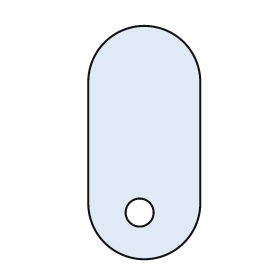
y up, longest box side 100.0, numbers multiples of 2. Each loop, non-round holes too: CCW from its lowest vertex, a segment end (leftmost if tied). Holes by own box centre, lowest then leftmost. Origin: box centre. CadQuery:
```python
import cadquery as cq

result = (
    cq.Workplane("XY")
    .moveTo(-24.0, -26.0)
    .threePointArc((0.0, -50.0), (24.0, -26.0))
    .lineTo(24.0, 26.0)
    .threePointArc((0.0, 50.0), (-24.0, 26.0))
    .close()
    .moveTo(-2.0, -30.0)
    .circle(6.0)
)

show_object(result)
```